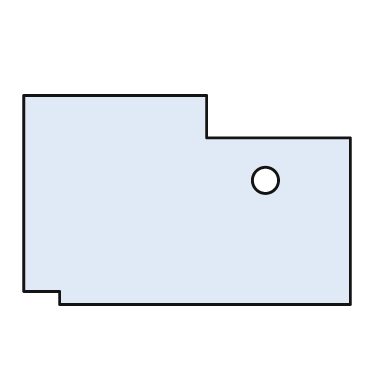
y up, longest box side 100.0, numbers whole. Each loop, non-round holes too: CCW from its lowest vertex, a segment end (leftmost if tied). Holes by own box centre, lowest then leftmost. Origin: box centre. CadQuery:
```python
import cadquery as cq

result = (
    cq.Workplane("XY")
    .moveTo(-39.0, -32.0)
    .lineTo(50.0, -32.0)
    .lineTo(50.0, 19.0)
    .lineTo(6.0, 19.0)
    .lineTo(6.0, 32.0)
    .lineTo(-50.0, 32.0)
    .lineTo(-50.0, -28.0)
    .lineTo(-39.0, -28.0)
    .close()
    .moveTo(24.0, 6.0)
    .circle(4.0)
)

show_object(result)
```